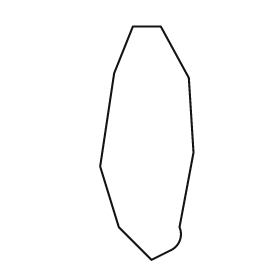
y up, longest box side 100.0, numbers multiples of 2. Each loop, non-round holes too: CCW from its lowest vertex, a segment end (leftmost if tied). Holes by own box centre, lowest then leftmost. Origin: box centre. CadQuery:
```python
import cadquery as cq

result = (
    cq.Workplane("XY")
    .moveTo(2.0, -50.0)
    .lineTo(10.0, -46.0)
    .threePointArc((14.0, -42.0), (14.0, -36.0))
    .lineTo(20.0, -4.0)
    .lineTo(18.0, 28.0)
    .lineTo(6.0, 50.0)
    .lineTo(-6.0, 50.0)
    .lineTo(-14.0, 30.0)
    .lineTo(-20.0, -10.0)
    .lineTo(-12.0, -36.0)
    .close()
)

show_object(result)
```